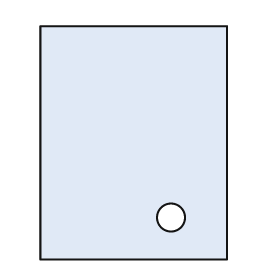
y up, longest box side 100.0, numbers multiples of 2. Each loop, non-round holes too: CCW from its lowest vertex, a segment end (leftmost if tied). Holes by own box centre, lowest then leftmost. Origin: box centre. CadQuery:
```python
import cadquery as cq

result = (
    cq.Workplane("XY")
    .moveTo(-40.0, -50.0)
    .lineTo(40.0, -50.0)
    .lineTo(40.0, 50.0)
    .lineTo(-40.0, 50.0)
    .close()
    .moveTo(16.0, -32.0)
    .circle(6.0)
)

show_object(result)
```